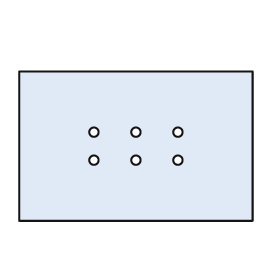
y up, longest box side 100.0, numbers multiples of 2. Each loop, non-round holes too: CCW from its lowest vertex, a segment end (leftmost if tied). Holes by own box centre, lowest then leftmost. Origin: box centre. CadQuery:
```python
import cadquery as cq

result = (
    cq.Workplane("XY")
    .moveTo(-50.0, -32.0)
    .lineTo(50.0, -32.0)
    .lineTo(50.0, 32.0)
    .lineTo(-50.0, 32.0)
    .close()
    .moveTo(-18.0, -6.0)
    .circle(2.0)
    .moveTo(0.0, -6.0)
    .circle(2.0)
    .moveTo(18.0, -6.0)
    .circle(2.0)
    .moveTo(-18.0, 6.0)
    .circle(2.0)
    .moveTo(0.0, 6.0)
    .circle(2.0)
    .moveTo(18.0, 6.0)
    .circle(2.0)
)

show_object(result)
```